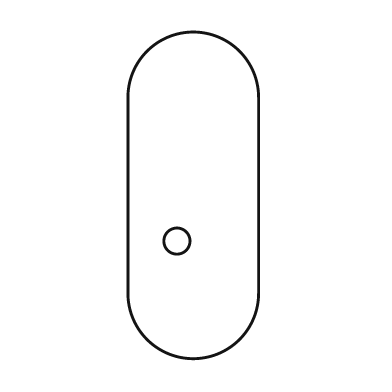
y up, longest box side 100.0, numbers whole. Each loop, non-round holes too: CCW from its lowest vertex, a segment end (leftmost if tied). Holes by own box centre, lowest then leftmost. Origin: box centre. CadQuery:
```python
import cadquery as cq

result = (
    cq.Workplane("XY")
    .moveTo(-20.0, -30.0)
    .threePointArc((0.0, -50.0), (20.0, -30.0))
    .lineTo(20.0, 30.0)
    .threePointArc((0.0, 50.0), (-20.0, 30.0))
    .close()
    .moveTo(-5.0, -14.0)
    .circle(4.0)
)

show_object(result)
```